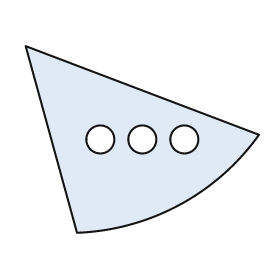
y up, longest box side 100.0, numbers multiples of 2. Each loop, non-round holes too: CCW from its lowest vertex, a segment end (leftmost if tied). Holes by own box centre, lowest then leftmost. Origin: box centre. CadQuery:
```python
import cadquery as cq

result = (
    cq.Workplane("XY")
    .moveTo(-28.0, -40.0)
    .threePointArc((16.0, -28.0), (50.0, 2.0))
    .lineTo(-50.0, 40.0)
    .close()
    .moveTo(-18.0, 0.0)
    .circle(6.0)
    .moveTo(0.0, 0.0)
    .circle(6.0)
    .moveTo(18.0, 0.0)
    .circle(6.0)
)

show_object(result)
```